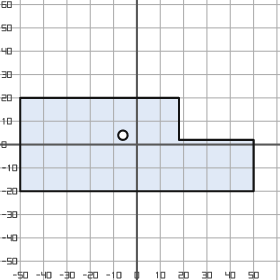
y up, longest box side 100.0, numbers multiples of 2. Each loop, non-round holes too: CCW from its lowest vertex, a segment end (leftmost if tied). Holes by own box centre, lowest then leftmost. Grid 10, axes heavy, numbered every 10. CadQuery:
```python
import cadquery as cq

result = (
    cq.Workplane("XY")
    .moveTo(-50.0, -20.0)
    .lineTo(50.0, -20.0)
    .lineTo(50.0, 2.0)
    .lineTo(18.0, 2.0)
    .lineTo(18.0, 20.0)
    .lineTo(-50.0, 20.0)
    .close()
    .moveTo(-6.0, 4.0)
    .circle(2.0)
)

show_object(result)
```